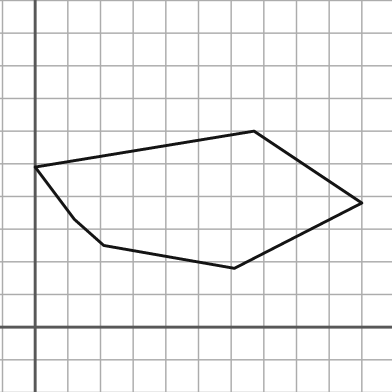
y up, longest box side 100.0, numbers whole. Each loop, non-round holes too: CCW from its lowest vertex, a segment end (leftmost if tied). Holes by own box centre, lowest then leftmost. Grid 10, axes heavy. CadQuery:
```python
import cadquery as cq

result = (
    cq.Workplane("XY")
    .moveTo(61.0, 18.0)
    .lineTo(100.0, 38.0)
    .lineTo(67.0, 60.0)
    .lineTo(0.0, 49.0)
    .lineTo(12.0, 33.0)
    .lineTo(21.0, 25.0)
    .close()
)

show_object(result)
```